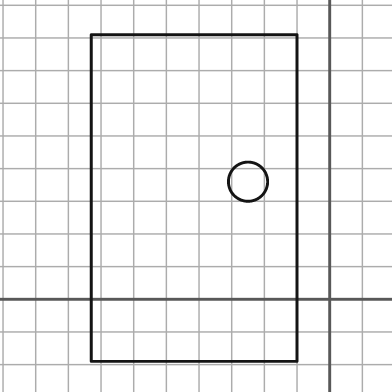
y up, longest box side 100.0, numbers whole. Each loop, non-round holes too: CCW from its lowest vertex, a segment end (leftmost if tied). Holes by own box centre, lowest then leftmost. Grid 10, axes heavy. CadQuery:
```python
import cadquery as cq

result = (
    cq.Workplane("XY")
    .moveTo(-73.0, -19.0)
    .lineTo(-10.0, -19.0)
    .lineTo(-10.0, 81.0)
    .lineTo(-73.0, 81.0)
    .close()
    .moveTo(-25.0, 36.0)
    .circle(6.0)
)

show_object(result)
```